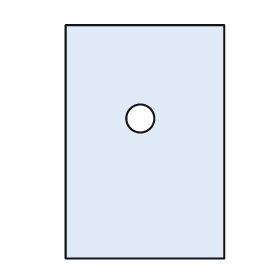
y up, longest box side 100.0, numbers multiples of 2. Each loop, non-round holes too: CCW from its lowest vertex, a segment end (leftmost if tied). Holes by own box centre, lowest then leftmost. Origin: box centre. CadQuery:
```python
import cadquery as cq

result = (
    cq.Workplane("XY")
    .moveTo(-34.0, -50.0)
    .lineTo(34.0, -50.0)
    .lineTo(34.0, 50.0)
    .lineTo(-34.0, 50.0)
    .close()
    .moveTo(-2.0, 10.0)
    .circle(6.0)
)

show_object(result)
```